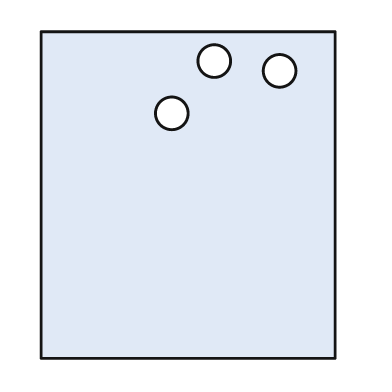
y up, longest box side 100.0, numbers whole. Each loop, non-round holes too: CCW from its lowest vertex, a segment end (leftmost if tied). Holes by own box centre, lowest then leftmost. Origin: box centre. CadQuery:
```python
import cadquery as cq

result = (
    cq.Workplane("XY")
    .moveTo(-45.0, -50.0)
    .lineTo(45.0, -50.0)
    .lineTo(45.0, 50.0)
    .lineTo(-45.0, 50.0)
    .close()
    .moveTo(-5.0, 25.0)
    .circle(5.0)
    .moveTo(28.0, 38.0)
    .circle(5.0)
    .moveTo(8.0, 41.0)
    .circle(5.0)
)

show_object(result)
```